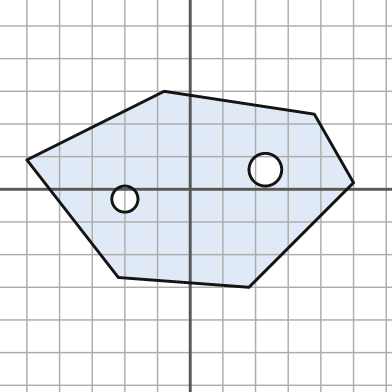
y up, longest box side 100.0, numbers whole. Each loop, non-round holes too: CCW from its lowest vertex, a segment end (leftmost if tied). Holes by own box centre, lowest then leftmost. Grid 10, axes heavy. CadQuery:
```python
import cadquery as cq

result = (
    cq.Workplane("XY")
    .moveTo(18.0, -30.0)
    .lineTo(50.0, 2.0)
    .lineTo(38.0, 23.0)
    .lineTo(-8.0, 30.0)
    .lineTo(-50.0, 9.0)
    .lineTo(-22.0, -27.0)
    .close()
    .moveTo(-20.0, -3.0)
    .circle(4.0)
    .moveTo(23.0, 6.0)
    .circle(5.0)
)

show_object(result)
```